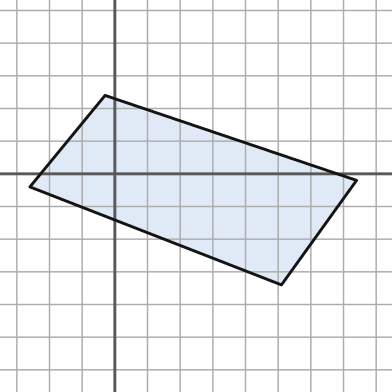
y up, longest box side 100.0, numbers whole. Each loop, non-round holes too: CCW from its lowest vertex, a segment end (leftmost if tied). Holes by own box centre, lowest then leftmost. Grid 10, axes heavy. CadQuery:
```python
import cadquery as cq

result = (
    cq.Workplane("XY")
    .moveTo(51.0, -34.0)
    .lineTo(74.0, -2.0)
    .lineTo(-3.0, 24.0)
    .lineTo(-26.0, -4.0)
    .close()
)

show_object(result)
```